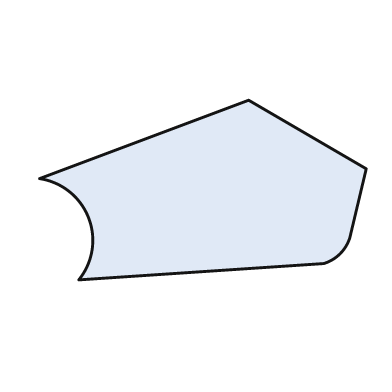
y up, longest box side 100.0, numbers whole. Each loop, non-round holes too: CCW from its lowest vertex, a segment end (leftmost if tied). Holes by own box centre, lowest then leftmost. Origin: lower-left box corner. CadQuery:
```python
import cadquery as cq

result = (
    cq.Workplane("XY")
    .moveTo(12.0, 0.0)
    .lineTo(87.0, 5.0)
    .threePointArc((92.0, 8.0), (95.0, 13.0))
    .lineTo(100.0, 34.0)
    .lineTo(64.0, 55.0)
    .lineTo(0.0, 31.0)
    .threePointArc((15.0, 19.0), (12.0, 0.0))
    .close()
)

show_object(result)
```